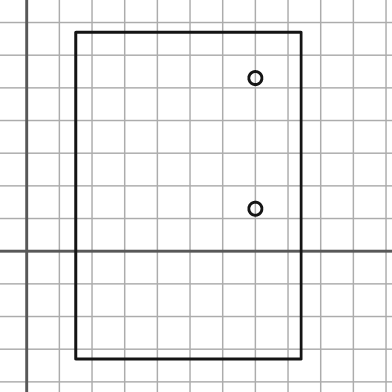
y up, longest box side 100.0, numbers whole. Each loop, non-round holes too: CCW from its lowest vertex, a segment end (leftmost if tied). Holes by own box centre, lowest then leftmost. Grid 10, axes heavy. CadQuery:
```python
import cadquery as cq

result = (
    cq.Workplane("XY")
    .moveTo(15.0, -33.0)
    .lineTo(84.0, -33.0)
    .lineTo(84.0, 67.0)
    .lineTo(15.0, 67.0)
    .close()
    .moveTo(70.0, 13.0)
    .circle(2.0)
    .moveTo(70.0, 53.0)
    .circle(2.0)
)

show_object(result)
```